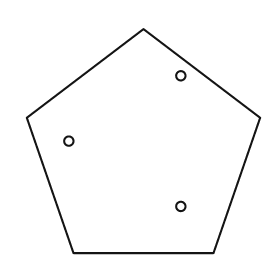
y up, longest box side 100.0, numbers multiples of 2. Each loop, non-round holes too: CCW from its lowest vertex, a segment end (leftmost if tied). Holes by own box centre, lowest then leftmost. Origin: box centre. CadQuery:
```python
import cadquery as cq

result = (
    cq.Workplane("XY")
    .moveTo(-30.0, -48.0)
    .lineTo(30.0, -48.0)
    .lineTo(50.0, 10.0)
    .lineTo(0.0, 48.0)
    .lineTo(-50.0, 10.0)
    .close()
    .moveTo(16.0, -28.0)
    .circle(2.0)
    .moveTo(-32.0, 0.0)
    .circle(2.0)
    .moveTo(16.0, 28.0)
    .circle(2.0)
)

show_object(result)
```